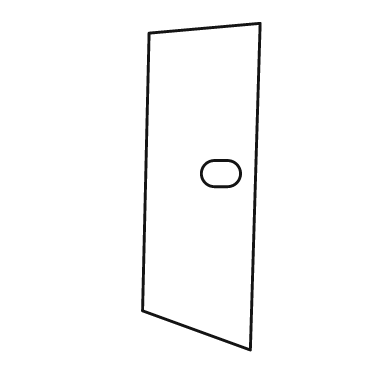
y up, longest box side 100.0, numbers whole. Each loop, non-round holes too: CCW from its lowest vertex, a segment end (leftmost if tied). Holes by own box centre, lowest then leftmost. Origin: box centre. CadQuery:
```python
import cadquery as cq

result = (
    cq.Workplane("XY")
    .moveTo(15.0, -50.0)
    .lineTo(18.0, 50.0)
    .lineTo(-16.0, 47.0)
    .lineTo(-18.0, -38.0)
    .close()
    .moveTo(4.0, 0.0)
    .lineTo(8.0, 0.0)
    .threePointArc((12.0, 4.0), (8.0, 8.0))
    .lineTo(4.0, 8.0)
    .threePointArc((0.0, 4.0), (4.0, 0.0))
    .close()
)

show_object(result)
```